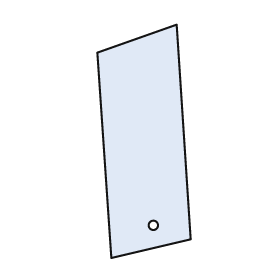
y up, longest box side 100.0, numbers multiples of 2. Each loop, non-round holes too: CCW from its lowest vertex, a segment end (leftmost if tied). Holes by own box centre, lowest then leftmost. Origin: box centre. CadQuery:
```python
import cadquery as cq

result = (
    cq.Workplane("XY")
    .moveTo(-14.0, -50.0)
    .lineTo(20.0, -42.0)
    .lineTo(14.0, 50.0)
    .lineTo(-20.0, 38.0)
    .close()
    .moveTo(4.0, -36.0)
    .circle(2.0)
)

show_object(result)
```